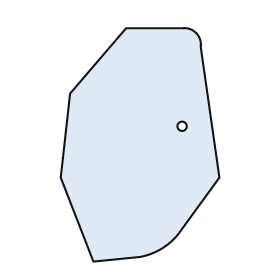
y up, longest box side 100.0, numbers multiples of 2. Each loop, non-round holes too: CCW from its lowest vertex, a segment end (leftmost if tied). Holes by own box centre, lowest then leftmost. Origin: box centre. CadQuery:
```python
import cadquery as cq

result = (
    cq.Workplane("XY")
    .moveTo(-20.0, -50.0)
    .lineTo(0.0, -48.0)
    .threePointArc((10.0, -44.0), (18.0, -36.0))
    .lineTo(34.0, -14.0)
    .lineTo(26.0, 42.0)
    .threePointArc((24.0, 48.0), (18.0, 50.0))
    .lineTo(-6.0, 50.0)
    .lineTo(-30.0, 22.0)
    .lineTo(-34.0, -14.0)
    .close()
    .moveTo(18.0, 8.0)
    .circle(2.0)
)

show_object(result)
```